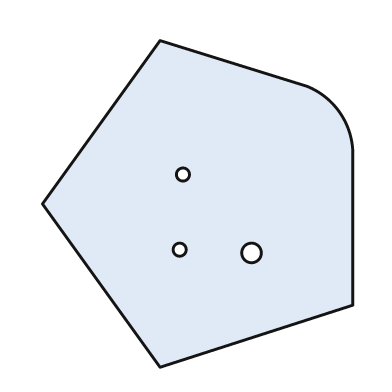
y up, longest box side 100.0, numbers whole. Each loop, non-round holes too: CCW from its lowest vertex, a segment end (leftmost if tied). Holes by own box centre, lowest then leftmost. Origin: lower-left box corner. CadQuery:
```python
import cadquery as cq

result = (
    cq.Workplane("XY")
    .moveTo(36.0, 0.0)
    .lineTo(95.0, 19.0)
    .lineTo(95.0, 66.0)
    .threePointArc((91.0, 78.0), (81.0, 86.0))
    .lineTo(36.0, 100.0)
    .lineTo(0.0, 50.0)
    .close()
    .moveTo(64.0, 35.0)
    .circle(3.0)
    .moveTo(42.0, 36.0)
    .circle(2.0)
    .moveTo(43.0, 59.0)
    .circle(2.0)
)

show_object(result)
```